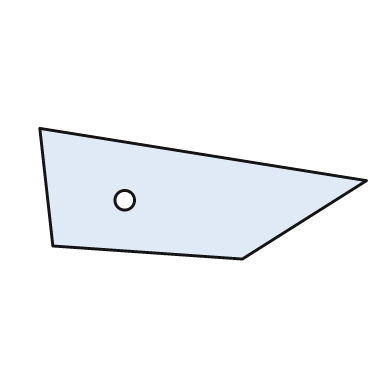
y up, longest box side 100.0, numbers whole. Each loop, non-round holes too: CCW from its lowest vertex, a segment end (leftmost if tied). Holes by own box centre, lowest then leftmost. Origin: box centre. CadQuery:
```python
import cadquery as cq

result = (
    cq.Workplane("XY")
    .moveTo(12.0, -20.0)
    .lineTo(50.0, 4.0)
    .lineTo(-50.0, 20.0)
    .lineTo(-46.0, -16.0)
    .close()
    .moveTo(-24.0, -2.0)
    .circle(3.0)
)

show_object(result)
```